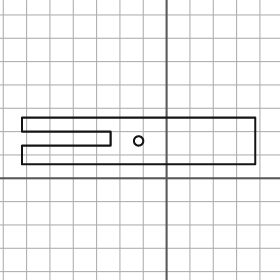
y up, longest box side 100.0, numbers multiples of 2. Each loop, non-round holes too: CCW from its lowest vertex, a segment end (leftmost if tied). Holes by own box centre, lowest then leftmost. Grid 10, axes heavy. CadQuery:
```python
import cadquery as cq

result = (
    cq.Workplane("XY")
    .moveTo(-62.0, 6.0)
    .lineTo(38.0, 6.0)
    .lineTo(38.0, 26.0)
    .lineTo(-62.0, 26.0)
    .lineTo(-62.0, 20.0)
    .lineTo(-24.0, 20.0)
    .lineTo(-24.0, 14.0)
    .lineTo(-62.0, 14.0)
    .close()
    .moveTo(-12.0, 16.0)
    .circle(2.0)
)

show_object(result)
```